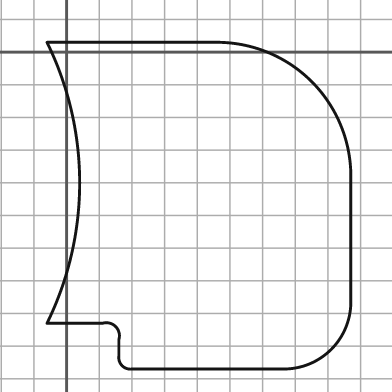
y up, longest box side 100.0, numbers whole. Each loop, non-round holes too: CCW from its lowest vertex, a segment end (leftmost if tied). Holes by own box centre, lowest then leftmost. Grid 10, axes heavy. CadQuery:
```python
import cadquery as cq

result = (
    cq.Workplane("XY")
    .moveTo(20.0, -97.0)
    .lineTo(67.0, -97.0)
    .threePointArc((81.0, -91.0), (87.0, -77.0))
    .lineTo(87.0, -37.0)
    .threePointArc((75.0, -9.0), (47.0, 3.0))
    .lineTo(-6.0, 3.0)
    .threePointArc((4.0, -40.0), (-6.0, -83.0))
    .lineTo(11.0, -83.0)
    .threePointArc((15.0, -84.0), (16.0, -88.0))
    .lineTo(16.0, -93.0)
    .threePointArc((17.0, -96.0), (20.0, -97.0))
    .close()
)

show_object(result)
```